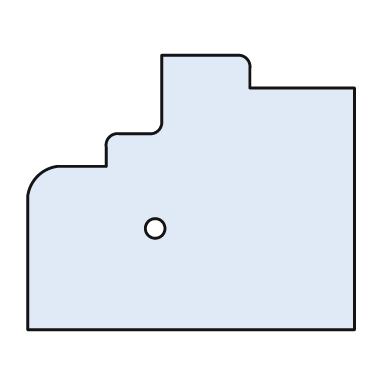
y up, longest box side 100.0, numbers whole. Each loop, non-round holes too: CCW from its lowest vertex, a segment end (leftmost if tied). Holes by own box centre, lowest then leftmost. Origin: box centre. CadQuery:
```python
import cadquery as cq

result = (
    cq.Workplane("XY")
    .moveTo(-50.0, -42.0)
    .lineTo(50.0, -42.0)
    .lineTo(50.0, 32.0)
    .lineTo(18.0, 32.0)
    .lineTo(18.0, 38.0)
    .threePointArc((17.0, 41.0), (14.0, 42.0))
    .lineTo(-9.0, 42.0)
    .lineTo(-9.0, 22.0)
    .threePointArc((-10.0, 19.0), (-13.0, 18.0))
    .lineTo(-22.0, 18.0)
    .threePointArc((-25.0, 17.0), (-26.0, 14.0))
    .lineTo(-26.0, 8.0)
    .lineTo(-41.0, 8.0)
    .threePointArc((-47.0, 5.0), (-50.0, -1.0))
    .close()
    .moveTo(-11.0, -11.0)
    .circle(3.0)
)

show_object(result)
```